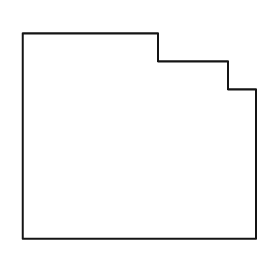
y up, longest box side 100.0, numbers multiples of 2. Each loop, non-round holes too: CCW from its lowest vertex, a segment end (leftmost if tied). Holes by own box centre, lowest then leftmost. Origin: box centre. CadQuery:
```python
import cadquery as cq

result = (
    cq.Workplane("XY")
    .moveTo(-50.0, -44.0)
    .lineTo(50.0, -44.0)
    .lineTo(50.0, 20.0)
    .lineTo(38.0, 20.0)
    .lineTo(38.0, 32.0)
    .lineTo(8.0, 32.0)
    .lineTo(8.0, 44.0)
    .lineTo(-50.0, 44.0)
    .close()
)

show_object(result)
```